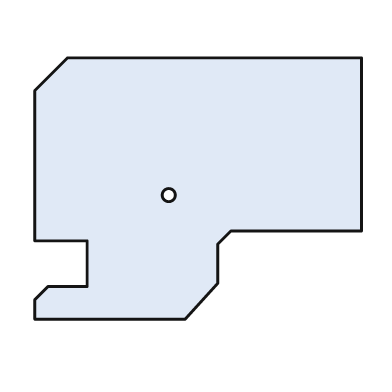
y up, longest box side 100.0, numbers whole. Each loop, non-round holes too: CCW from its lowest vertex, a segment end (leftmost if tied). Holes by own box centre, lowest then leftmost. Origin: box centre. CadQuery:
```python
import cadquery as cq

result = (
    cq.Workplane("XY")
    .moveTo(-50.0, -40.0)
    .lineTo(-4.0, -40.0)
    .lineTo(6.0, -29.0)
    .lineTo(6.0, -17.0)
    .lineTo(10.0, -13.0)
    .lineTo(50.0, -13.0)
    .lineTo(50.0, 40.0)
    .lineTo(-40.0, 40.0)
    .lineTo(-50.0, 30.0)
    .lineTo(-50.0, -16.0)
    .lineTo(-34.0, -16.0)
    .lineTo(-34.0, -30.0)
    .lineTo(-46.0, -30.0)
    .lineTo(-50.0, -34.0)
    .close()
    .moveTo(-9.0, -2.0)
    .circle(2.0)
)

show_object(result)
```